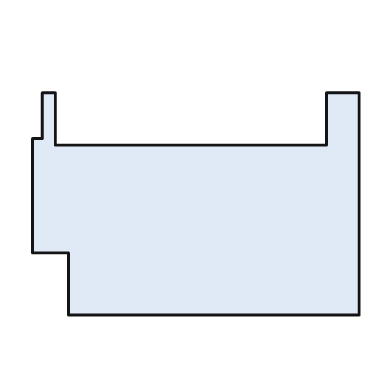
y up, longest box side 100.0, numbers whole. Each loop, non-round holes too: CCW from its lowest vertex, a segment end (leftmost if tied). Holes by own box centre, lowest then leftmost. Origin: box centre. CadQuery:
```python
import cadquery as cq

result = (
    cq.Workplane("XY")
    .moveTo(-39.0, -34.0)
    .lineTo(50.0, -34.0)
    .lineTo(50.0, 34.0)
    .lineTo(40.0, 34.0)
    .lineTo(40.0, 18.0)
    .lineTo(-43.0, 18.0)
    .lineTo(-43.0, 34.0)
    .lineTo(-47.0, 34.0)
    .lineTo(-47.0, 20.0)
    .lineTo(-50.0, 20.0)
    .lineTo(-50.0, -15.0)
    .lineTo(-39.0, -15.0)
    .close()
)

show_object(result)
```